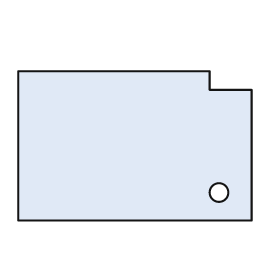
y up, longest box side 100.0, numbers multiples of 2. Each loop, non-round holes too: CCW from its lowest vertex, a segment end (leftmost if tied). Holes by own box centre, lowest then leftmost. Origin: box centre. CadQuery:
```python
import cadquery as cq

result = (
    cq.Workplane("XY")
    .moveTo(-50.0, -32.0)
    .lineTo(50.0, -32.0)
    .lineTo(50.0, 24.0)
    .lineTo(32.0, 24.0)
    .lineTo(32.0, 32.0)
    .lineTo(-50.0, 32.0)
    .close()
    .moveTo(36.0, -20.0)
    .circle(4.0)
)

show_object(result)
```